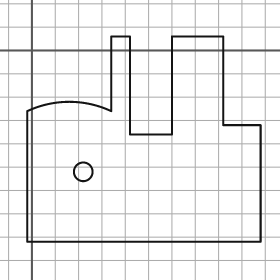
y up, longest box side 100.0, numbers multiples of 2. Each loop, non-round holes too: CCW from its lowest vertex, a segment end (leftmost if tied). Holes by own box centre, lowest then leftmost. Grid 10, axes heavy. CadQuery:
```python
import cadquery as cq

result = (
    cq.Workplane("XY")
    .moveTo(-2.0, -82.0)
    .lineTo(98.0, -82.0)
    .lineTo(98.0, -32.0)
    .lineTo(82.0, -32.0)
    .lineTo(82.0, 6.0)
    .lineTo(60.0, 6.0)
    .lineTo(60.0, -36.0)
    .lineTo(42.0, -36.0)
    .lineTo(42.0, 6.0)
    .lineTo(34.0, 6.0)
    .lineTo(34.0, -26.0)
    .threePointArc((16.0, -22.0), (-2.0, -26.0))
    .close()
    .moveTo(22.0, -52.0)
    .circle(4.0)
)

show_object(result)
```